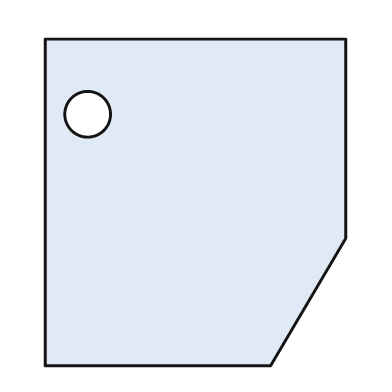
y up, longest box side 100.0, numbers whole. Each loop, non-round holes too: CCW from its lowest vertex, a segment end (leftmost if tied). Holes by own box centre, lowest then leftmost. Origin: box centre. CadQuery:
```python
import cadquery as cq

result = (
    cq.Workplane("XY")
    .moveTo(-46.0, -50.0)
    .lineTo(23.0, -50.0)
    .lineTo(46.0, -11.0)
    .lineTo(46.0, 50.0)
    .lineTo(-46.0, 50.0)
    .close()
    .moveTo(-33.0, 27.0)
    .circle(7.0)
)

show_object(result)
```